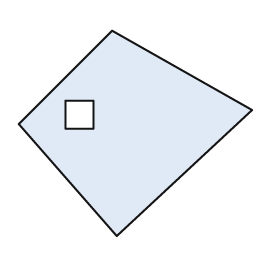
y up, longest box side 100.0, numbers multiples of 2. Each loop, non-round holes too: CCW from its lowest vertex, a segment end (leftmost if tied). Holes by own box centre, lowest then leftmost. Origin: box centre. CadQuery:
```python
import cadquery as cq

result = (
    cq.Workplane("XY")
    .moveTo(-8.0, -44.0)
    .lineTo(50.0, 10.0)
    .lineTo(-10.0, 44.0)
    .lineTo(-50.0, 4.0)
    .close()
    .moveTo(-30.0, 2.0)
    .lineTo(-18.0, 2.0)
    .lineTo(-18.0, 14.0)
    .lineTo(-30.0, 14.0)
    .close()
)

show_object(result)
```